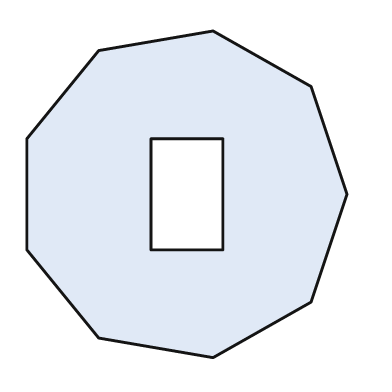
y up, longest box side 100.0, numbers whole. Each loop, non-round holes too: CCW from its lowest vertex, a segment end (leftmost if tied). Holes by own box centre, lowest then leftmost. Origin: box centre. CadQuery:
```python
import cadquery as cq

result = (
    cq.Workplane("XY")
    .moveTo(8.0, -50.0)
    .lineTo(38.0, -33.0)
    .lineTo(49.0, 0.0)
    .lineTo(38.0, 33.0)
    .lineTo(8.0, 50.0)
    .lineTo(-27.0, 44.0)
    .lineTo(-49.0, 17.0)
    .lineTo(-49.0, -17.0)
    .lineTo(-27.0, -44.0)
    .close()
    .moveTo(-11.0, -17.0)
    .lineTo(11.0, -17.0)
    .lineTo(11.0, 17.0)
    .lineTo(-11.0, 17.0)
    .close()
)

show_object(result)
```